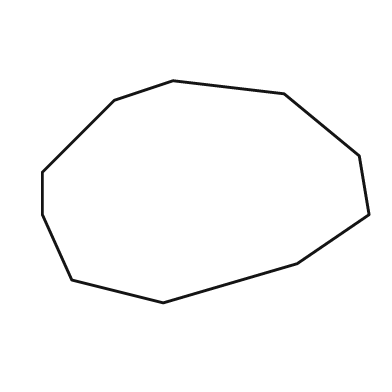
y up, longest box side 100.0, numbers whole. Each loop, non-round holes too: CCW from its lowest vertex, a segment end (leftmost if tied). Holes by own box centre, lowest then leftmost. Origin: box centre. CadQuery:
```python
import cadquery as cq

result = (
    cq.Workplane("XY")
    .moveTo(-13.0, -34.0)
    .lineTo(28.0, -22.0)
    .lineTo(50.0, -7.0)
    .lineTo(47.0, 11.0)
    .lineTo(24.0, 30.0)
    .lineTo(-10.0, 34.0)
    .lineTo(-28.0, 28.0)
    .lineTo(-50.0, 6.0)
    .lineTo(-50.0, -7.0)
    .lineTo(-41.0, -27.0)
    .close()
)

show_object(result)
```